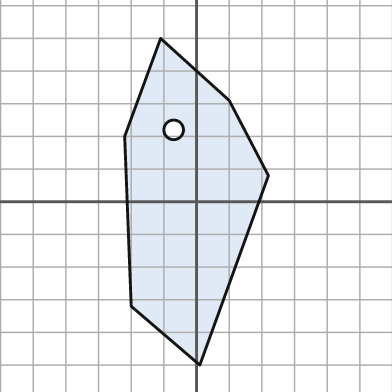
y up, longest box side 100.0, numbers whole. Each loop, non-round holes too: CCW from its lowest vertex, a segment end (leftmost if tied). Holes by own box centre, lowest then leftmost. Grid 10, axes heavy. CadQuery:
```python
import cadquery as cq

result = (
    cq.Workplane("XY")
    .moveTo(1.0, -50.0)
    .lineTo(22.0, 8.0)
    .lineTo(10.0, 31.0)
    .lineTo(-11.0, 50.0)
    .lineTo(-22.0, 20.0)
    .lineTo(-20.0, -32.0)
    .close()
    .moveTo(-7.0, 22.0)
    .circle(3.0)
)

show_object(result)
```